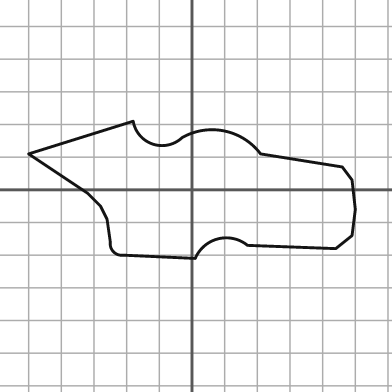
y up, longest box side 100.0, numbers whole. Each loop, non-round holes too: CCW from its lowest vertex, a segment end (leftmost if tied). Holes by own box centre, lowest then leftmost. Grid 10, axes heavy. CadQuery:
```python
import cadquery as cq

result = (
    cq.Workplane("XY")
    .moveTo(1.0, -21.0)
    .threePointArc((8.0, -15.0), (17.0, -17.0))
    .lineTo(44.0, -18.0)
    .lineTo(49.0, -14.0)
    .lineTo(50.0, -6.0)
    .lineTo(49.0, 3.0)
    .lineTo(46.0, 7.0)
    .lineTo(21.0, 11.0)
    .threePointArc((10.0, 18.0), (-3.0, 16.0))
    .threePointArc((-12.0, 14.0), (-18.0, 21.0))
    .lineTo(-50.0, 11.0)
    .lineTo(-32.0, -1.0)
    .lineTo(-28.0, -5.0)
    .lineTo(-26.0, -9.0)
    .lineTo(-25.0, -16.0)
    .threePointArc((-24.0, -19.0), (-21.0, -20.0))
    .close()
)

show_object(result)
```